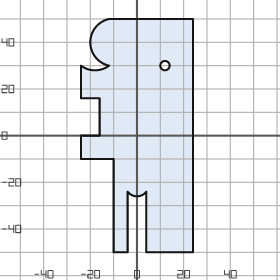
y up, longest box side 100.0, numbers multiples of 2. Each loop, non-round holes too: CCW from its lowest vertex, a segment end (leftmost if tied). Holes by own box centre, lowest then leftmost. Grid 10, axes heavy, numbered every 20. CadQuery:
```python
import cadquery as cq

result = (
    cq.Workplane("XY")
    .moveTo(-10.0, -50.0)
    .lineTo(-4.0, -50.0)
    .lineTo(-4.0, -24.0)
    .threePointArc((0.0, -26.0), (4.0, -24.0))
    .lineTo(4.0, -50.0)
    .lineTo(24.0, -50.0)
    .lineTo(24.0, 50.0)
    .lineTo(-12.0, 50.0)
    .threePointArc((-20.0, 40.0), (-12.0, 30.0))
    .threePointArc((-18.0, 28.0), (-24.0, 30.0))
    .lineTo(-24.0, 16.0)
    .lineTo(-16.0, 16.0)
    .lineTo(-16.0, 0.0)
    .lineTo(-24.0, 0.0)
    .lineTo(-24.0, -10.0)
    .lineTo(-10.0, -10.0)
    .close()
    .moveTo(12.0, 30.0)
    .circle(2.0)
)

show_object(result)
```